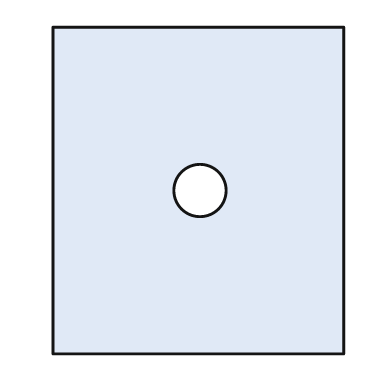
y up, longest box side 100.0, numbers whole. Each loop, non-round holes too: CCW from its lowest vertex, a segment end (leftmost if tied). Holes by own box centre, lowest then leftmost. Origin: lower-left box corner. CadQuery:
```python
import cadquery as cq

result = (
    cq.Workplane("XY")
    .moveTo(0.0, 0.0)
    .lineTo(89.0, 0.0)
    .lineTo(89.0, 100.0)
    .lineTo(0.0, 100.0)
    .close()
    .moveTo(45.0, 50.0)
    .circle(8.0)
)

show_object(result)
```